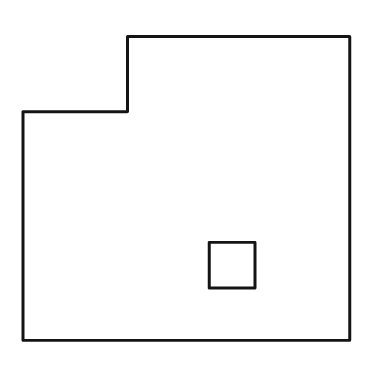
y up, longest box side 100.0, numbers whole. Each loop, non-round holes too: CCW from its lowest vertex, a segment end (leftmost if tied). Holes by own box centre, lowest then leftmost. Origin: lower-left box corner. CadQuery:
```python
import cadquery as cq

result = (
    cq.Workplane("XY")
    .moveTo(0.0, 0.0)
    .lineTo(100.0, 0.0)
    .lineTo(100.0, 93.0)
    .lineTo(32.0, 93.0)
    .lineTo(32.0, 70.0)
    .lineTo(0.0, 70.0)
    .close()
    .moveTo(57.0, 16.0)
    .lineTo(71.0, 16.0)
    .lineTo(71.0, 30.0)
    .lineTo(57.0, 30.0)
    .close()
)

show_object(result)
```